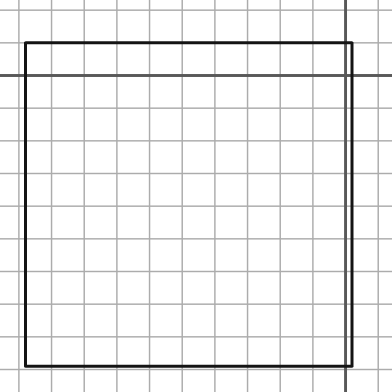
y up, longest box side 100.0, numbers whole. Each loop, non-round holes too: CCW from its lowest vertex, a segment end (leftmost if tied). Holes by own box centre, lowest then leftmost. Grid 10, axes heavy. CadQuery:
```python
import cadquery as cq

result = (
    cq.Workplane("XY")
    .moveTo(-98.0, -89.0)
    .lineTo(2.0, -89.0)
    .lineTo(2.0, 10.0)
    .lineTo(-98.0, 10.0)
    .close()
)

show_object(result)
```